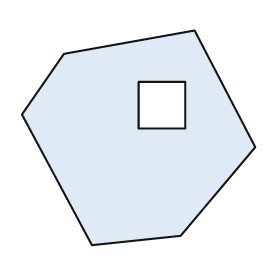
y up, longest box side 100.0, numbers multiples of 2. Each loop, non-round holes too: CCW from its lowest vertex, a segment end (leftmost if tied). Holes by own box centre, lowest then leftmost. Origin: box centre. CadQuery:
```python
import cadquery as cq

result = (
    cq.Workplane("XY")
    .moveTo(-20.0, -46.0)
    .lineTo(18.0, -42.0)
    .lineTo(50.0, -4.0)
    .lineTo(24.0, 46.0)
    .lineTo(-32.0, 36.0)
    .lineTo(-50.0, 10.0)
    .close()
    .moveTo(0.0, 4.0)
    .lineTo(20.0, 4.0)
    .lineTo(20.0, 24.0)
    .lineTo(0.0, 24.0)
    .close()
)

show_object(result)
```